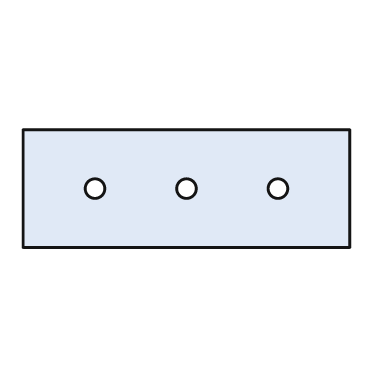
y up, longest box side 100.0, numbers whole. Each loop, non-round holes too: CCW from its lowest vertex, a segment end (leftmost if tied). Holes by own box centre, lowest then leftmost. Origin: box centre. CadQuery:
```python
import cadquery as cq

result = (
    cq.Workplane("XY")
    .moveTo(-50.0, -18.0)
    .lineTo(50.0, -18.0)
    .lineTo(50.0, 18.0)
    .lineTo(-50.0, 18.0)
    .close()
    .moveTo(-28.0, 0.0)
    .circle(3.0)
    .moveTo(0.0, 0.0)
    .circle(3.0)
    .moveTo(28.0, 0.0)
    .circle(3.0)
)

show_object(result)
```